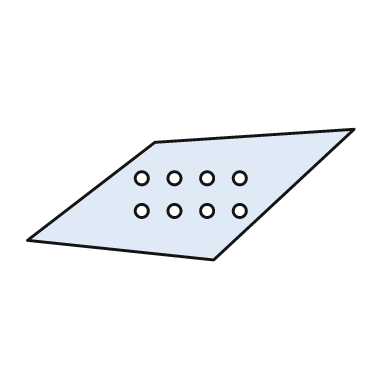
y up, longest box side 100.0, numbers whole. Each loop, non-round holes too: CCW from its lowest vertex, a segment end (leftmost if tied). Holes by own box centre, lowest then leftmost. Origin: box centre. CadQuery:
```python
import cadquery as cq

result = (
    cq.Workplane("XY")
    .moveTo(7.0, -20.0)
    .lineTo(50.0, 20.0)
    .lineTo(-11.0, 16.0)
    .lineTo(-50.0, -14.0)
    .close()
    .moveTo(-15.0, -5.0)
    .circle(2.0)
    .moveTo(-5.0, -5.0)
    .circle(2.0)
    .moveTo(5.0, -5.0)
    .circle(2.0)
    .moveTo(15.0, -5.0)
    .circle(2.0)
    .moveTo(-15.0, 5.0)
    .circle(2.0)
    .moveTo(-5.0, 5.0)
    .circle(2.0)
    .moveTo(5.0, 5.0)
    .circle(2.0)
    .moveTo(15.0, 5.0)
    .circle(2.0)
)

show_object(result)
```